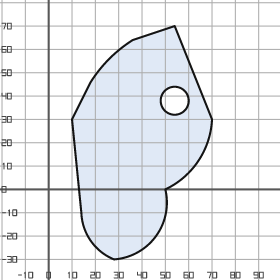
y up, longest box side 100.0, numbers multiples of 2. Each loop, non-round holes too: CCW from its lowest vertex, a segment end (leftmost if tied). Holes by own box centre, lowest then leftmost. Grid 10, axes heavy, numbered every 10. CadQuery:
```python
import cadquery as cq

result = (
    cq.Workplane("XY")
    .moveTo(28.0, -30.0)
    .threePointArc((46.0, -20.0), (50.0, 0.0))
    .threePointArc((64.0, 12.0), (70.0, 30.0))
    .lineTo(54.0, 70.0)
    .lineTo(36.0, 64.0)
    .threePointArc((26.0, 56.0), (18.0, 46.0))
    .lineTo(10.0, 30.0)
    .lineTo(14.0, -10.0)
    .threePointArc((18.0, -22.0), (28.0, -30.0))
    .close()
    .moveTo(54.0, 38.0)
    .circle(6.0)
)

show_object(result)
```